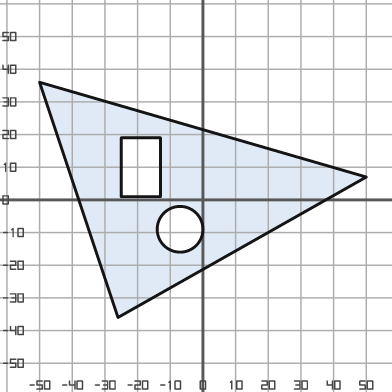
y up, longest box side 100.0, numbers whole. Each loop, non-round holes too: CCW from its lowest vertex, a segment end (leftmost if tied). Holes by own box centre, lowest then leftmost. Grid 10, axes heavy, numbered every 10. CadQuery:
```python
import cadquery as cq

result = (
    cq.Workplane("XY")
    .moveTo(-26.0, -36.0)
    .lineTo(50.0, 7.0)
    .lineTo(-50.0, 36.0)
    .close()
    .moveTo(-7.0, -9.0)
    .circle(7.0)
    .moveTo(-25.0, 1.0)
    .lineTo(-13.0, 1.0)
    .lineTo(-13.0, 19.0)
    .lineTo(-25.0, 19.0)
    .close()
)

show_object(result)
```